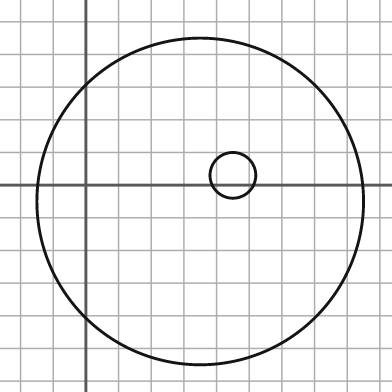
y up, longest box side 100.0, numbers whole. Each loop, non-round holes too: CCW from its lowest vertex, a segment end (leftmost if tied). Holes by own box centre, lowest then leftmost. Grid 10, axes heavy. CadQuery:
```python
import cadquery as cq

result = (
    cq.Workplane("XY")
    .moveTo(35.0, -5.0)
    .circle(50.0)
    .moveTo(45.0, 3.0)
    .circle(7.0)
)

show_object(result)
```